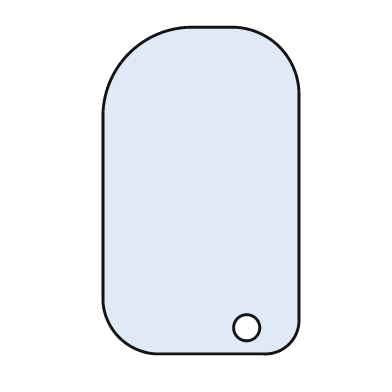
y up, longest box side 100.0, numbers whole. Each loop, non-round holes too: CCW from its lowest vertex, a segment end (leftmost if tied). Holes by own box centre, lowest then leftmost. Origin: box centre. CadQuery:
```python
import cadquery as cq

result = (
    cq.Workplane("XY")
    .moveTo(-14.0, -50.0)
    .lineTo(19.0, -50.0)
    .threePointArc((27.0, -47.0), (30.0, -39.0))
    .lineTo(30.0, 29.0)
    .threePointArc((24.0, 44.0), (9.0, 50.0))
    .lineTo(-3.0, 50.0)
    .threePointArc((-22.0, 42.0), (-30.0, 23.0))
    .lineTo(-30.0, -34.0)
    .threePointArc((-25.0, -45.0), (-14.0, -50.0))
    .close()
    .moveTo(14.0, -42.0)
    .circle(4.0)
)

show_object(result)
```